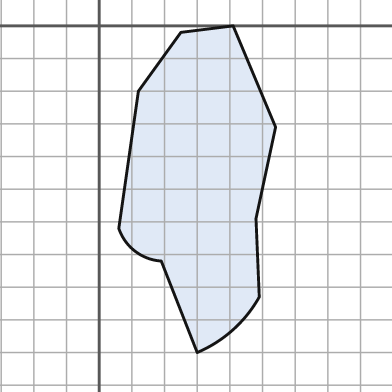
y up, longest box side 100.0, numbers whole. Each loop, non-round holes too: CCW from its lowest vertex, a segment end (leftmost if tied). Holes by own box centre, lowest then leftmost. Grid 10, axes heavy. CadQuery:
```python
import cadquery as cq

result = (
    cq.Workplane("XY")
    .moveTo(30.0, -100.0)
    .threePointArc((41.0, -93.0), (49.0, -83.0))
    .lineTo(48.0, -59.0)
    .lineTo(54.0, -31.0)
    .lineTo(41.0, 0.0)
    .lineTo(25.0, -2.0)
    .lineTo(12.0, -20.0)
    .lineTo(6.0, -62.0)
    .threePointArc((11.0, -69.0), (19.0, -72.0))
    .close()
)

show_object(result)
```